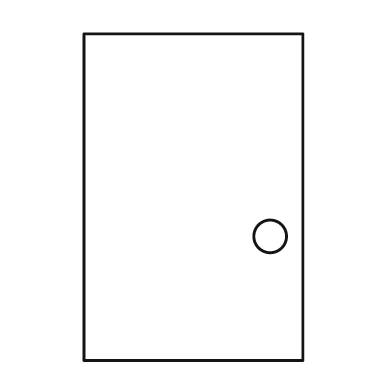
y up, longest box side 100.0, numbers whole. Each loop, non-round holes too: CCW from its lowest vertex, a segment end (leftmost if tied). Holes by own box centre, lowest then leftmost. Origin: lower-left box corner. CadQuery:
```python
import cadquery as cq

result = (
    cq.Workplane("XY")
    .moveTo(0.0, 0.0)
    .lineTo(67.0, 0.0)
    .lineTo(67.0, 100.0)
    .lineTo(0.0, 100.0)
    .close()
    .moveTo(57.0, 38.0)
    .circle(5.0)
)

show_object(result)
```